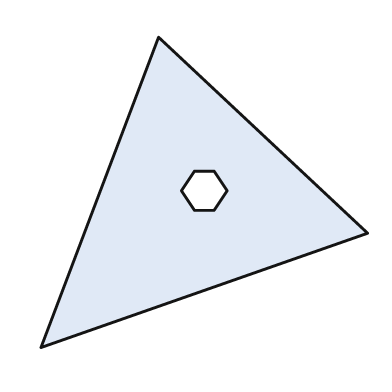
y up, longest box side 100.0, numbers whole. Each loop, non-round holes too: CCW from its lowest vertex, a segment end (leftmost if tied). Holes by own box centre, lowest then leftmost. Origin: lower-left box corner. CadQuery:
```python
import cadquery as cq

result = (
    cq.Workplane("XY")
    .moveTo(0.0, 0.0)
    .lineTo(100.0, 35.0)
    .lineTo(36.0, 95.0)
    .close()
    .moveTo(47.0, 42.0)
    .lineTo(53.0, 42.0)
    .lineTo(57.0, 48.0)
    .lineTo(53.0, 54.0)
    .lineTo(47.0, 54.0)
    .lineTo(43.0, 48.0)
    .close()
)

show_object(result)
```